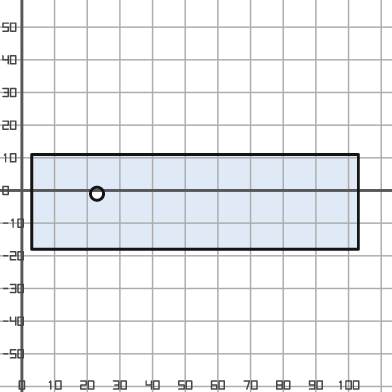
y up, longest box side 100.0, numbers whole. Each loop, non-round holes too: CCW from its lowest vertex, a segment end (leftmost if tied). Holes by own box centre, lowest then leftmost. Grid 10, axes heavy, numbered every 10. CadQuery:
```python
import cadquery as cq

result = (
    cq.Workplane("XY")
    .moveTo(3.0, -18.0)
    .lineTo(103.0, -18.0)
    .lineTo(103.0, 11.0)
    .lineTo(3.0, 11.0)
    .close()
    .moveTo(23.0, -1.0)
    .circle(2.0)
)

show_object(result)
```